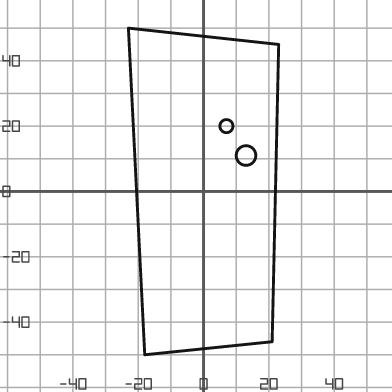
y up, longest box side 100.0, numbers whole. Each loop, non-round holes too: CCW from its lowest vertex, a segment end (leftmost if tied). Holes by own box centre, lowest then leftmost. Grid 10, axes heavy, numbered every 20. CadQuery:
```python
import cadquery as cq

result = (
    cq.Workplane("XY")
    .moveTo(-18.0, -50.0)
    .lineTo(21.0, -46.0)
    .lineTo(23.0, 45.0)
    .lineTo(-23.0, 50.0)
    .close()
    .moveTo(13.0, 11.0)
    .circle(3.0)
    .moveTo(7.0, 20.0)
    .circle(2.0)
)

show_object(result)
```